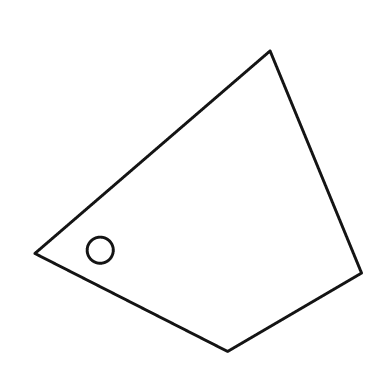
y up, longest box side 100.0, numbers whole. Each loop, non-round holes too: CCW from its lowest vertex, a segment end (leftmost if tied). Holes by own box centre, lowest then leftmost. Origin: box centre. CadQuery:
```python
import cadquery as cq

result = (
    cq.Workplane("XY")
    .moveTo(9.0, -46.0)
    .lineTo(50.0, -22.0)
    .lineTo(22.0, 46.0)
    .lineTo(-50.0, -16.0)
    .close()
    .moveTo(-30.0, -15.0)
    .circle(4.0)
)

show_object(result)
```